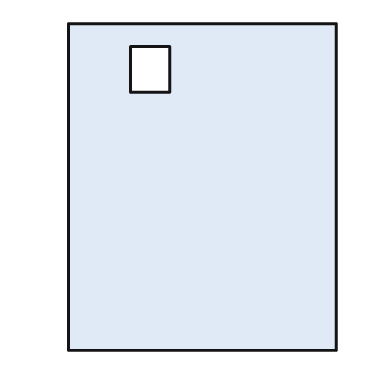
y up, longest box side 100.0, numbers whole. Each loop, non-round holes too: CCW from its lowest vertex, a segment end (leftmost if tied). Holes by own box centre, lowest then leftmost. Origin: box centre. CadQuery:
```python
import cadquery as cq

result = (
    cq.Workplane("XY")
    .moveTo(-41.0, -50.0)
    .lineTo(41.0, -50.0)
    .lineTo(41.0, 50.0)
    .lineTo(-41.0, 50.0)
    .close()
    .moveTo(-22.0, 29.0)
    .lineTo(-10.0, 29.0)
    .lineTo(-10.0, 43.0)
    .lineTo(-22.0, 43.0)
    .close()
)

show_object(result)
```